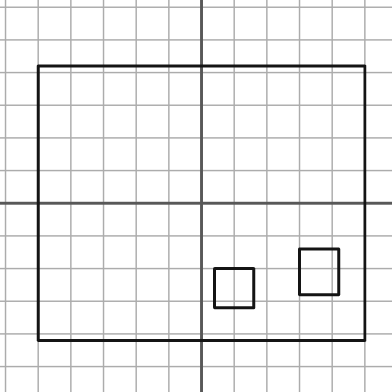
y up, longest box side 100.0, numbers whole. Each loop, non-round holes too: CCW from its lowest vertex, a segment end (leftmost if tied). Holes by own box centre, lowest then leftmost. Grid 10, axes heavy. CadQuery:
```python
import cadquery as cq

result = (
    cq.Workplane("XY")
    .moveTo(-50.0, -42.0)
    .lineTo(50.0, -42.0)
    .lineTo(50.0, 42.0)
    .lineTo(-50.0, 42.0)
    .close()
    .moveTo(4.0, -32.0)
    .lineTo(16.0, -32.0)
    .lineTo(16.0, -20.0)
    .lineTo(4.0, -20.0)
    .close()
    .moveTo(30.0, -28.0)
    .lineTo(42.0, -28.0)
    .lineTo(42.0, -14.0)
    .lineTo(30.0, -14.0)
    .close()
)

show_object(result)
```